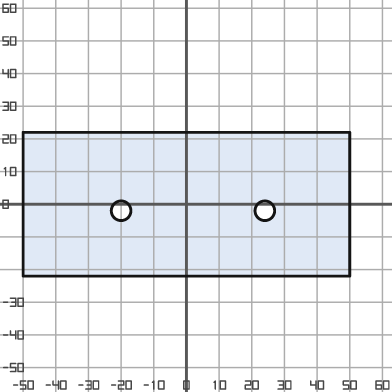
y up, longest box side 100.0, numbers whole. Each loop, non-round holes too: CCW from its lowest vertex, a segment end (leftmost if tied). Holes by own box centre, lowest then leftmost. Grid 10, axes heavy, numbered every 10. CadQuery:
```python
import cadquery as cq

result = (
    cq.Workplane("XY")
    .moveTo(-50.0, -22.0)
    .lineTo(50.0, -22.0)
    .lineTo(50.0, 22.0)
    .lineTo(-50.0, 22.0)
    .close()
    .moveTo(-20.0, -2.0)
    .circle(3.0)
    .moveTo(24.0, -2.0)
    .circle(3.0)
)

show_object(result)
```